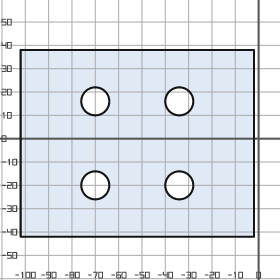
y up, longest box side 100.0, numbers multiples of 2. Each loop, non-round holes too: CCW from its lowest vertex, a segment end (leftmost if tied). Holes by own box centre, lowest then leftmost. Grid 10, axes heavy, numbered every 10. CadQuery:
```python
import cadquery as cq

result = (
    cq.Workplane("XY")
    .moveTo(-102.0, -42.0)
    .lineTo(-2.0, -42.0)
    .lineTo(-2.0, 38.0)
    .lineTo(-102.0, 38.0)
    .close()
    .moveTo(-70.0, -20.0)
    .circle(6.0)
    .moveTo(-34.0, -20.0)
    .circle(6.0)
    .moveTo(-70.0, 16.0)
    .circle(6.0)
    .moveTo(-34.0, 16.0)
    .circle(6.0)
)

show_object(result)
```